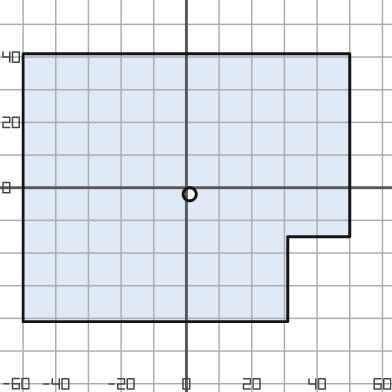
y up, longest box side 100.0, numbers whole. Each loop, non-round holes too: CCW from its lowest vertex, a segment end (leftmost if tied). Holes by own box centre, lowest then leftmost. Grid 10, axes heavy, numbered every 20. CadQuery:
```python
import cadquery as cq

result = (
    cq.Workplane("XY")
    .moveTo(-50.0, -41.0)
    .lineTo(31.0, -41.0)
    .lineTo(31.0, -15.0)
    .lineTo(50.0, -15.0)
    .lineTo(50.0, 41.0)
    .lineTo(-50.0, 41.0)
    .close()
    .moveTo(1.0, -2.0)
    .circle(2.0)
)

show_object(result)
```